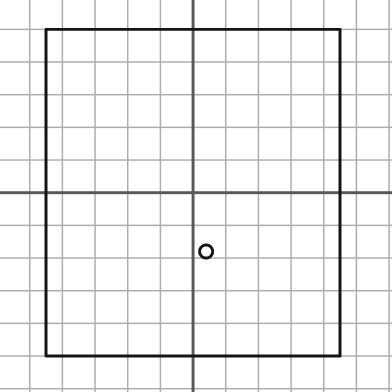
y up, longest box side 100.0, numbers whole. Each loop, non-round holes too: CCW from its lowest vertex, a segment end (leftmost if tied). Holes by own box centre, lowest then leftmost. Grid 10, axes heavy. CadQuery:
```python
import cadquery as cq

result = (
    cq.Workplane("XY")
    .moveTo(-45.0, -50.0)
    .lineTo(45.0, -50.0)
    .lineTo(45.0, 50.0)
    .lineTo(-45.0, 50.0)
    .close()
    .moveTo(4.0, -18.0)
    .circle(2.0)
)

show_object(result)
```